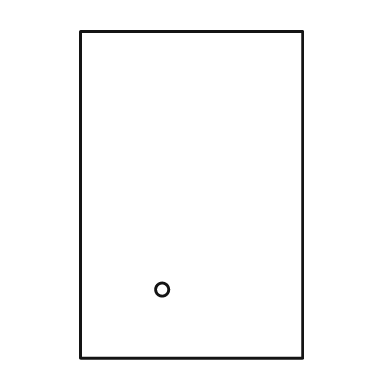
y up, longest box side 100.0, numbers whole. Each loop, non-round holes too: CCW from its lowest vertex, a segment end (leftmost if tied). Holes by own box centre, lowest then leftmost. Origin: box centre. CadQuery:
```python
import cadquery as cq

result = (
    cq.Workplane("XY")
    .moveTo(-34.0, -50.0)
    .lineTo(34.0, -50.0)
    .lineTo(34.0, 50.0)
    .lineTo(-34.0, 50.0)
    .close()
    .moveTo(-9.0, -29.0)
    .circle(2.0)
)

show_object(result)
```